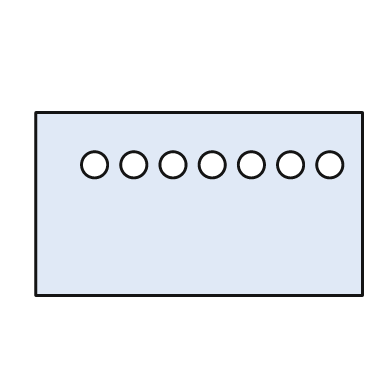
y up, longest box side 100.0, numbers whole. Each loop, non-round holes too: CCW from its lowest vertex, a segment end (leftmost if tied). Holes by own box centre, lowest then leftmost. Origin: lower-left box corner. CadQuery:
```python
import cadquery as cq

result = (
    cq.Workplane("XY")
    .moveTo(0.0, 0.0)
    .lineTo(100.0, 0.0)
    .lineTo(100.0, 56.0)
    .lineTo(0.0, 56.0)
    .close()
    .moveTo(18.0, 40.0)
    .circle(4.0)
    .moveTo(30.0, 40.0)
    .circle(4.0)
    .moveTo(42.0, 40.0)
    .circle(4.0)
    .moveTo(54.0, 40.0)
    .circle(4.0)
    .moveTo(66.0, 40.0)
    .circle(4.0)
    .moveTo(78.0, 40.0)
    .circle(4.0)
    .moveTo(90.0, 40.0)
    .circle(4.0)
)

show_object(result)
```